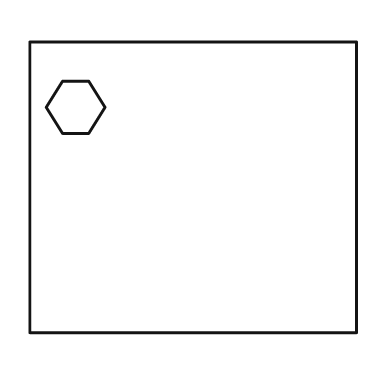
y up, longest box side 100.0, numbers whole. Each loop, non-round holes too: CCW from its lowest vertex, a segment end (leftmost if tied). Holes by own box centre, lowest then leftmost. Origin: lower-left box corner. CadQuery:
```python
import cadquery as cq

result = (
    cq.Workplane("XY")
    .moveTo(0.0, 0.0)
    .lineTo(100.0, 0.0)
    .lineTo(100.0, 89.0)
    .lineTo(0.0, 89.0)
    .close()
    .moveTo(10.0, 61.0)
    .lineTo(18.0, 61.0)
    .lineTo(23.0, 69.0)
    .lineTo(18.0, 77.0)
    .lineTo(10.0, 77.0)
    .lineTo(5.0, 69.0)
    .close()
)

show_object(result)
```